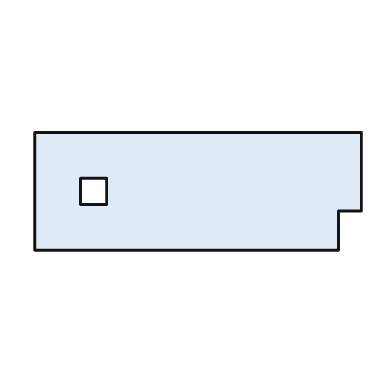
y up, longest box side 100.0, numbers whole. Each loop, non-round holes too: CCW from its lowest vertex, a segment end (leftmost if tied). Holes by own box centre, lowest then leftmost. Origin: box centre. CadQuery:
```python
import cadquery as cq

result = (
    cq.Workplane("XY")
    .moveTo(-50.0, -18.0)
    .lineTo(43.0, -18.0)
    .lineTo(43.0, -6.0)
    .lineTo(50.0, -6.0)
    .lineTo(50.0, 18.0)
    .lineTo(-50.0, 18.0)
    .close()
    .moveTo(-36.0, -4.0)
    .lineTo(-28.0, -4.0)
    .lineTo(-28.0, 4.0)
    .lineTo(-36.0, 4.0)
    .close()
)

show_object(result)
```